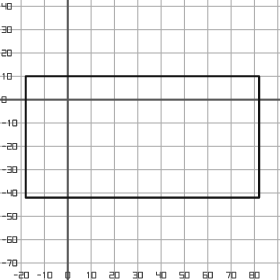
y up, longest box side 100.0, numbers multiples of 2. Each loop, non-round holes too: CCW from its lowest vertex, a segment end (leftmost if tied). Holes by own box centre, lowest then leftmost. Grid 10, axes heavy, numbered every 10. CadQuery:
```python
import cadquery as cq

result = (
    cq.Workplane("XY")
    .moveTo(-18.0, -42.0)
    .lineTo(82.0, -42.0)
    .lineTo(82.0, 10.0)
    .lineTo(-18.0, 10.0)
    .close()
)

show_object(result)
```